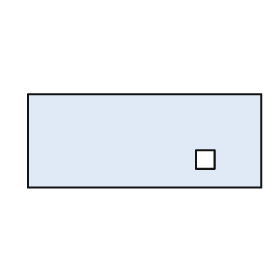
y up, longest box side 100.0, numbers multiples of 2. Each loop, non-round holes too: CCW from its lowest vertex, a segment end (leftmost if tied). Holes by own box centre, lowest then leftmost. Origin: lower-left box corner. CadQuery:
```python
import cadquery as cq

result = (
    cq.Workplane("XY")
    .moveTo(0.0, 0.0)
    .lineTo(100.0, 0.0)
    .lineTo(100.0, 40.0)
    .lineTo(0.0, 40.0)
    .close()
    .moveTo(72.0, 8.0)
    .lineTo(80.0, 8.0)
    .lineTo(80.0, 16.0)
    .lineTo(72.0, 16.0)
    .close()
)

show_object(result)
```